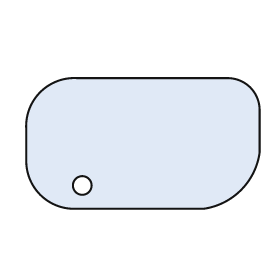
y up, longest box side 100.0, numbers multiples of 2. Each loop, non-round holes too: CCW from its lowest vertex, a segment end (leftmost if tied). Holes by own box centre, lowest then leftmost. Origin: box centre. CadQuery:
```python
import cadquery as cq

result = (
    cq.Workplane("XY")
    .moveTo(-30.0, -28.0)
    .lineTo(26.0, -28.0)
    .threePointArc((42.0, -20.0), (50.0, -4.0))
    .lineTo(50.0, 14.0)
    .threePointArc((46.0, 24.0), (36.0, 28.0))
    .lineTo(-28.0, 28.0)
    .threePointArc((-44.0, 22.0), (-50.0, 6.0))
    .lineTo(-50.0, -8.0)
    .threePointArc((-44.0, -22.0), (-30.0, -28.0))
    .close()
    .moveTo(-26.0, -18.0)
    .circle(4.0)
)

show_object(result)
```